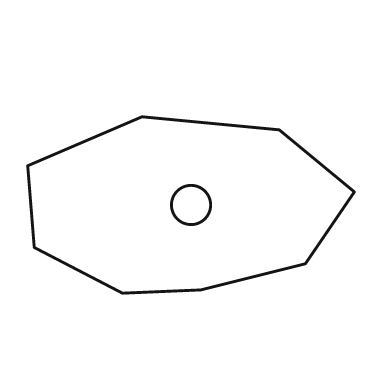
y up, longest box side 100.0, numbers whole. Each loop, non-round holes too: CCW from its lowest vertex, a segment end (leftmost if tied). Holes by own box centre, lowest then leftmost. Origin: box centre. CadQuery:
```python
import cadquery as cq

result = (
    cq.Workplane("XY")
    .moveTo(-21.0, -27.0)
    .lineTo(3.0, -26.0)
    .lineTo(35.0, -18.0)
    .lineTo(50.0, 4.0)
    .lineTo(27.0, 23.0)
    .lineTo(-15.0, 27.0)
    .lineTo(-50.0, 12.0)
    .lineTo(-48.0, -13.0)
    .close()
    .moveTo(0.0, 0.0)
    .circle(6.0)
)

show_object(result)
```